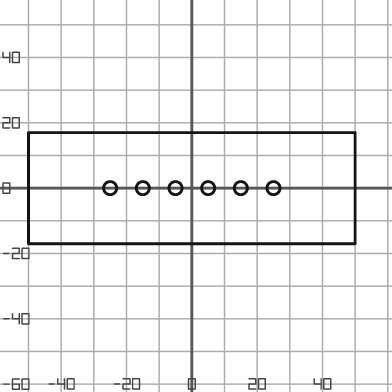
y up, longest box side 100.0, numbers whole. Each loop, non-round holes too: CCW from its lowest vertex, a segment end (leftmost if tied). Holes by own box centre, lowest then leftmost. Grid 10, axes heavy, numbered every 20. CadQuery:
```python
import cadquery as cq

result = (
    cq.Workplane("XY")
    .moveTo(-50.0, -17.0)
    .lineTo(50.0, -17.0)
    .lineTo(50.0, 17.0)
    .lineTo(-50.0, 17.0)
    .close()
    .moveTo(-25.0, 0.0)
    .circle(2.0)
    .moveTo(-15.0, 0.0)
    .circle(2.0)
    .moveTo(-5.0, 0.0)
    .circle(2.0)
    .moveTo(5.0, 0.0)
    .circle(2.0)
    .moveTo(15.0, 0.0)
    .circle(2.0)
    .moveTo(25.0, 0.0)
    .circle(2.0)
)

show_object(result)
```